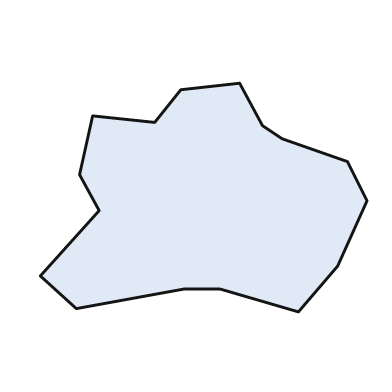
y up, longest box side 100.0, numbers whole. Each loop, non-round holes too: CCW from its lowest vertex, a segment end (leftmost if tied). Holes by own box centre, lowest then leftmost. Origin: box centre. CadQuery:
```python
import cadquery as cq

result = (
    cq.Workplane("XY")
    .moveTo(29.0, -35.0)
    .lineTo(41.0, -21.0)
    .lineTo(50.0, -1.0)
    .lineTo(44.0, 11.0)
    .lineTo(24.0, 18.0)
    .lineTo(18.0, 22.0)
    .lineTo(11.0, 35.0)
    .lineTo(-7.0, 33.0)
    .lineTo(-15.0, 23.0)
    .lineTo(-34.0, 25.0)
    .lineTo(-38.0, 7.0)
    .lineTo(-32.0, -4.0)
    .lineTo(-50.0, -24.0)
    .lineTo(-39.0, -34.0)
    .lineTo(-6.0, -28.0)
    .lineTo(5.0, -28.0)
    .close()
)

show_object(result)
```